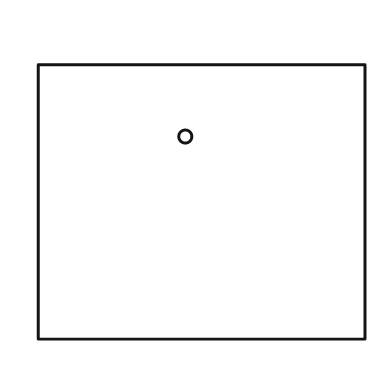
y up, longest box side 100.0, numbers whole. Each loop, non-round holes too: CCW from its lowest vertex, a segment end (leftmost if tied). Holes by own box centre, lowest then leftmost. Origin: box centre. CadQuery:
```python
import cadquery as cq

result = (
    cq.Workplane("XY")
    .moveTo(-50.0, -42.0)
    .lineTo(50.0, -42.0)
    .lineTo(50.0, 42.0)
    .lineTo(-50.0, 42.0)
    .close()
    .moveTo(-5.0, 20.0)
    .circle(2.0)
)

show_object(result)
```